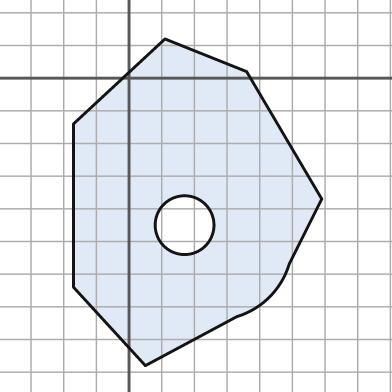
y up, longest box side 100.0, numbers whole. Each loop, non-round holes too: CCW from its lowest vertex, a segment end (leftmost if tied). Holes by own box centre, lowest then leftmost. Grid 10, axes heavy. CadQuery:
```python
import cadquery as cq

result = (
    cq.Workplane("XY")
    .moveTo(5.0, -88.0)
    .lineTo(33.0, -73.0)
    .threePointArc((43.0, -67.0), (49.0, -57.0))
    .lineTo(59.0, -37.0)
    .lineTo(36.0, 2.0)
    .lineTo(11.0, 12.0)
    .lineTo(-17.0, -14.0)
    .lineTo(-17.0, -64.0)
    .close()
    .moveTo(17.0, -45.0)
    .circle(9.0)
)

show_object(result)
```